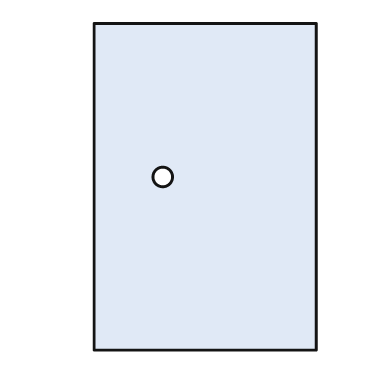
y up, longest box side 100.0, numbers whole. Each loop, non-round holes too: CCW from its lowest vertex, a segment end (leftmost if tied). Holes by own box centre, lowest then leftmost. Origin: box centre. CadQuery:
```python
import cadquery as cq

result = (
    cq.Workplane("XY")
    .moveTo(-34.0, -50.0)
    .lineTo(34.0, -50.0)
    .lineTo(34.0, 50.0)
    .lineTo(-34.0, 50.0)
    .close()
    .moveTo(-13.0, 3.0)
    .circle(3.0)
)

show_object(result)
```